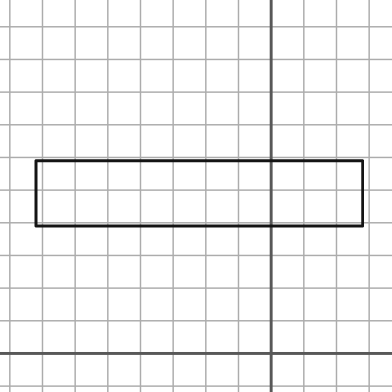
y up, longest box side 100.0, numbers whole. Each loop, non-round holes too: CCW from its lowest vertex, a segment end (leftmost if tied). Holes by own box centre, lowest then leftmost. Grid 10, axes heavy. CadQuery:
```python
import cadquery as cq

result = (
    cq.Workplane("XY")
    .moveTo(-72.0, 39.0)
    .lineTo(28.0, 39.0)
    .lineTo(28.0, 59.0)
    .lineTo(-72.0, 59.0)
    .close()
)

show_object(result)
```